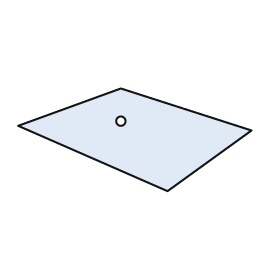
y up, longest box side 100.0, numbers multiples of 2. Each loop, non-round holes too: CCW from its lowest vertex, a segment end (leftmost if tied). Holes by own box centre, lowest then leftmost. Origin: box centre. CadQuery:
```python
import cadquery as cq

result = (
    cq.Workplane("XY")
    .moveTo(14.0, -22.0)
    .lineTo(50.0, 4.0)
    .lineTo(-6.0, 22.0)
    .lineTo(-50.0, 6.0)
    .close()
    .moveTo(-6.0, 8.0)
    .circle(2.0)
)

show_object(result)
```